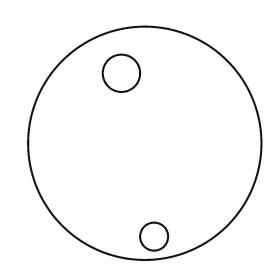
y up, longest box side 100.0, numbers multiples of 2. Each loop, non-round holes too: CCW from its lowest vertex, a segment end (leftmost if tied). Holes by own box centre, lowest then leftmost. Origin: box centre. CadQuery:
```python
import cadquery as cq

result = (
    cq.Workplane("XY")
    .moveTo(0.0, 0.0)
    .circle(50.0)
    .moveTo(4.0, -40.0)
    .circle(6.0)
    .moveTo(-10.0, 30.0)
    .circle(8.0)
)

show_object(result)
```